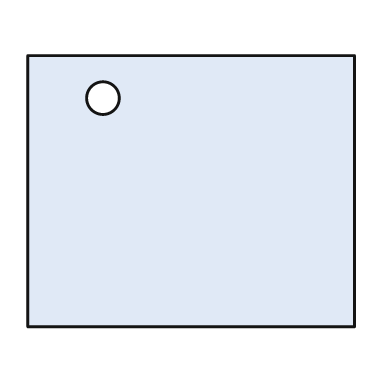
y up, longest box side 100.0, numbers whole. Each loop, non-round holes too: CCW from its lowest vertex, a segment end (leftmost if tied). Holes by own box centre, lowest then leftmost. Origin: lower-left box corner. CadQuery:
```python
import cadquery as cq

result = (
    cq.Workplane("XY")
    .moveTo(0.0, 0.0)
    .lineTo(100.0, 0.0)
    .lineTo(100.0, 83.0)
    .lineTo(0.0, 83.0)
    .close()
    .moveTo(23.0, 70.0)
    .circle(5.0)
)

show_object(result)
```